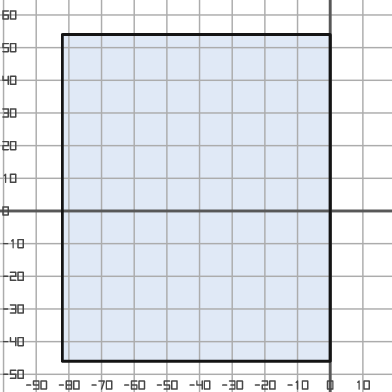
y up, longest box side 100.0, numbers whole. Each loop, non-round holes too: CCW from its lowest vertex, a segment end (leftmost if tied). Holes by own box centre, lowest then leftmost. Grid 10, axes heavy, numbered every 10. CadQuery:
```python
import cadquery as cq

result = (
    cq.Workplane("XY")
    .moveTo(-82.0, -46.0)
    .lineTo(0.0, -46.0)
    .lineTo(0.0, 54.0)
    .lineTo(-82.0, 54.0)
    .close()
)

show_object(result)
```